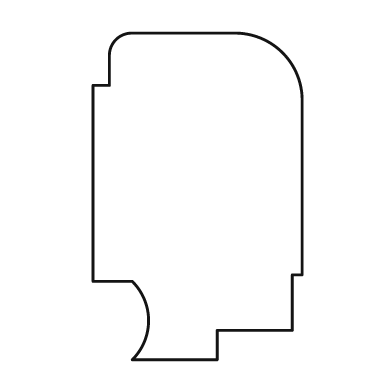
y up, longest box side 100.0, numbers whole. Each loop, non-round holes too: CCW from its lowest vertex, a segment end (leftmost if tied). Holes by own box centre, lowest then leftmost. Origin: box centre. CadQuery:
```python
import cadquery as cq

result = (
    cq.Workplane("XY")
    .moveTo(-20.0, -50.0)
    .lineTo(6.0, -50.0)
    .lineTo(6.0, -41.0)
    .lineTo(29.0, -41.0)
    .lineTo(29.0, -24.0)
    .lineTo(32.0, -24.0)
    .lineTo(32.0, 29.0)
    .threePointArc((26.0, 44.0), (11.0, 50.0))
    .lineTo(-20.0, 50.0)
    .threePointArc((-25.0, 48.0), (-27.0, 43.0))
    .lineTo(-27.0, 34.0)
    .lineTo(-32.0, 34.0)
    .lineTo(-32.0, -26.0)
    .lineTo(-20.0, -26.0)
    .threePointArc((-15.0, -38.0), (-20.0, -50.0))
    .close()
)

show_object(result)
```